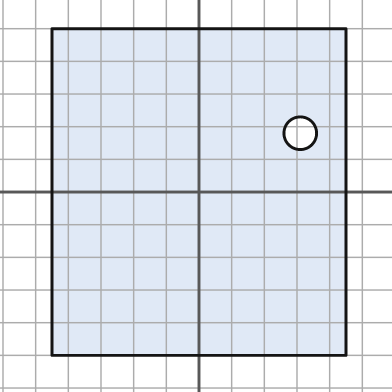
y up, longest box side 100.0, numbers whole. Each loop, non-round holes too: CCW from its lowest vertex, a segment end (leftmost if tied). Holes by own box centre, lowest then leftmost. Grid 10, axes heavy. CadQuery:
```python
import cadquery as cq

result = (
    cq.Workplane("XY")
    .moveTo(-45.0, -50.0)
    .lineTo(45.0, -50.0)
    .lineTo(45.0, 50.0)
    .lineTo(-45.0, 50.0)
    .close()
    .moveTo(31.0, 18.0)
    .circle(5.0)
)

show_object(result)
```